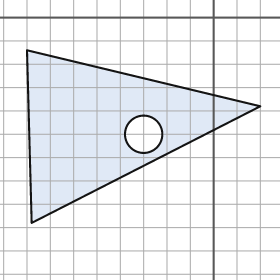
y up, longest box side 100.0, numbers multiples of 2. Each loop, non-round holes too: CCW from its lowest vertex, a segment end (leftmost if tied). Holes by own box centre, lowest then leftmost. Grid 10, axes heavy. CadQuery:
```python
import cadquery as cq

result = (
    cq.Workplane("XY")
    .moveTo(-78.0, -88.0)
    .lineTo(20.0, -38.0)
    .lineTo(-80.0, -14.0)
    .close()
    .moveTo(-30.0, -50.0)
    .circle(8.0)
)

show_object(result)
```